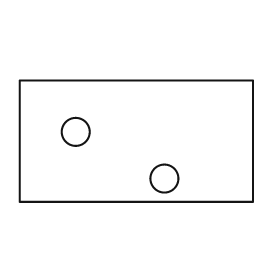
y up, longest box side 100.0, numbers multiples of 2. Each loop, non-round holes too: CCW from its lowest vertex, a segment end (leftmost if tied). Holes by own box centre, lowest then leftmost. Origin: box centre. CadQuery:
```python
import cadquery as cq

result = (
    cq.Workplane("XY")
    .moveTo(-50.0, -26.0)
    .lineTo(50.0, -26.0)
    .lineTo(50.0, 26.0)
    .lineTo(-50.0, 26.0)
    .close()
    .moveTo(12.0, -16.0)
    .circle(6.0)
    .moveTo(-26.0, 4.0)
    .circle(6.0)
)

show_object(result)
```